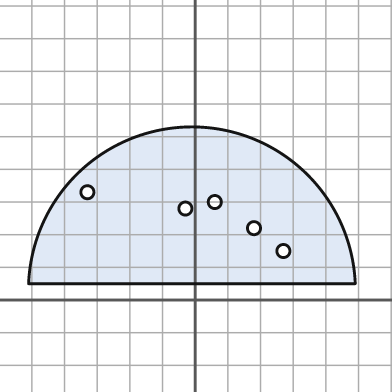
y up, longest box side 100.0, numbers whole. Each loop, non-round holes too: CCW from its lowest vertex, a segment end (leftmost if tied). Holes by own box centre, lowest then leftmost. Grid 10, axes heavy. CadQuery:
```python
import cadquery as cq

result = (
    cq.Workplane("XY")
    .moveTo(-51.0, 5.0)
    .lineTo(49.0, 5.0)
    .threePointArc((-1.0, 53.0), (-51.0, 5.0))
    .close()
    .moveTo(27.0, 15.0)
    .circle(2.0)
    .moveTo(18.0, 22.0)
    .circle(2.0)
    .moveTo(-3.0, 28.0)
    .circle(2.0)
    .moveTo(6.0, 30.0)
    .circle(2.0)
    .moveTo(-33.0, 33.0)
    .circle(2.0)
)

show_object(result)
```